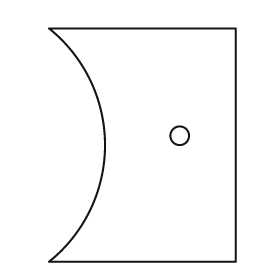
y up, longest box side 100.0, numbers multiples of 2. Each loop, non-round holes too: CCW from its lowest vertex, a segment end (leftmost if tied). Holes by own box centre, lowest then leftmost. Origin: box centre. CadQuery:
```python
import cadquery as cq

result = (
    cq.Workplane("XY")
    .moveTo(-40.0, -50.0)
    .lineTo(40.0, -50.0)
    .lineTo(40.0, 50.0)
    .lineTo(-40.0, 50.0)
    .threePointArc((-16.0, 0.0), (-40.0, -50.0))
    .close()
    .moveTo(16.0, 4.0)
    .circle(4.0)
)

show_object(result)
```